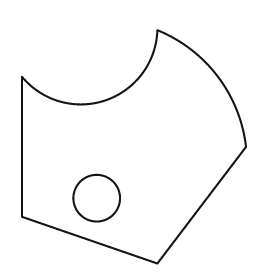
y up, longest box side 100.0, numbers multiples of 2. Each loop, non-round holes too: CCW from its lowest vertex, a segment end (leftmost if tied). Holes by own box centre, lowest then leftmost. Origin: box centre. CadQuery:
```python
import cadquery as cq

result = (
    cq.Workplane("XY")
    .moveTo(10.0, -50.0)
    .lineTo(48.0, 0.0)
    .threePointArc((36.0, 30.0), (10.0, 50.0))
    .threePointArc((-12.0, 20.0), (-48.0, 30.0))
    .lineTo(-48.0, -30.0)
    .close()
    .moveTo(-16.0, -22.0)
    .circle(10.0)
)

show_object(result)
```